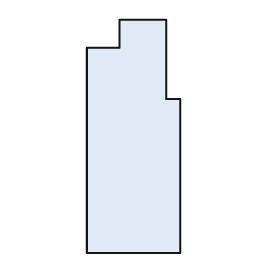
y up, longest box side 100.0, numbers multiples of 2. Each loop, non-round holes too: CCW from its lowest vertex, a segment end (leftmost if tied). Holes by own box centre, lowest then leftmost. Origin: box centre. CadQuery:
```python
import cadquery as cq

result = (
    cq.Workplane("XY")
    .moveTo(-20.0, -50.0)
    .lineTo(20.0, -50.0)
    .lineTo(20.0, 16.0)
    .lineTo(14.0, 16.0)
    .lineTo(14.0, 50.0)
    .lineTo(-6.0, 50.0)
    .lineTo(-6.0, 38.0)
    .lineTo(-20.0, 38.0)
    .close()
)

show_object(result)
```